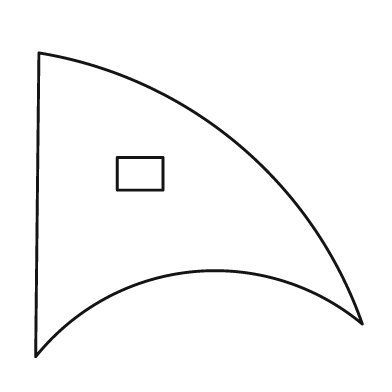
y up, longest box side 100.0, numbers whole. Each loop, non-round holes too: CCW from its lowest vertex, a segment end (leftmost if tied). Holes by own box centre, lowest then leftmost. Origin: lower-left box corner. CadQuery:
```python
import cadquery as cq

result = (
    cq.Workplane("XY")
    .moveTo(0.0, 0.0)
    .threePointArc((48.0, 26.0), (100.0, 10.0))
    .threePointArc((62.0, 65.0), (1.0, 93.0))
    .close()
    .moveTo(25.0, 51.0)
    .lineTo(39.0, 51.0)
    .lineTo(39.0, 61.0)
    .lineTo(25.0, 61.0)
    .close()
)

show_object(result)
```